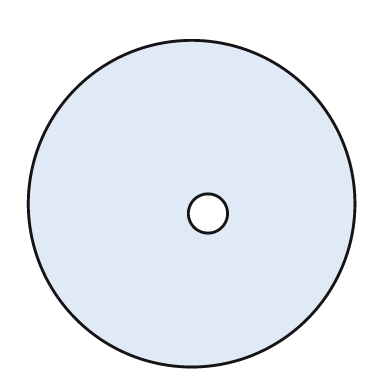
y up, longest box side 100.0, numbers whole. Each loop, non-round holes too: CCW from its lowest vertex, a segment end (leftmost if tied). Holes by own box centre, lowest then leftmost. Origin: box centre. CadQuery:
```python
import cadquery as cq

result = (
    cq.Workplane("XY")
    .moveTo(0.0, 0.0)
    .circle(50.0)
    .moveTo(5.0, -3.0)
    .circle(6.0)
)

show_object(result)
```